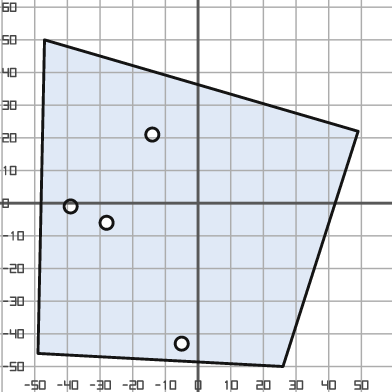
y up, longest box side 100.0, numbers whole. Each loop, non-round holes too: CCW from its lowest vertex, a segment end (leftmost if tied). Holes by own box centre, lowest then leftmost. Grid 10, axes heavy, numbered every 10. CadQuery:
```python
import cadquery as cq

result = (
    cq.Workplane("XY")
    .moveTo(26.0, -50.0)
    .lineTo(49.0, 22.0)
    .lineTo(-47.0, 50.0)
    .lineTo(-49.0, -46.0)
    .close()
    .moveTo(-5.0, -43.0)
    .circle(2.0)
    .moveTo(-28.0, -6.0)
    .circle(2.0)
    .moveTo(-39.0, -1.0)
    .circle(2.0)
    .moveTo(-14.0, 21.0)
    .circle(2.0)
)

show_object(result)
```